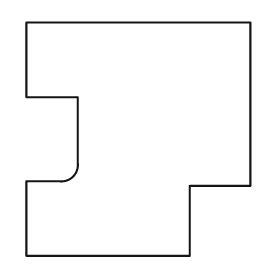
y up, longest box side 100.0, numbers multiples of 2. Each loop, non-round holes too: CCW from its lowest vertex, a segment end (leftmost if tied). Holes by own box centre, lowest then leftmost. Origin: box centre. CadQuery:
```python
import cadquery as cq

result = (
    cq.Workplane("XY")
    .moveTo(-48.0, -50.0)
    .lineTo(22.0, -50.0)
    .lineTo(22.0, -20.0)
    .lineTo(48.0, -20.0)
    .lineTo(48.0, 50.0)
    .lineTo(-48.0, 50.0)
    .lineTo(-48.0, 18.0)
    .lineTo(-26.0, 18.0)
    .lineTo(-26.0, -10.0)
    .threePointArc((-28.0, -16.0), (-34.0, -18.0))
    .lineTo(-48.0, -18.0)
    .close()
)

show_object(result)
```